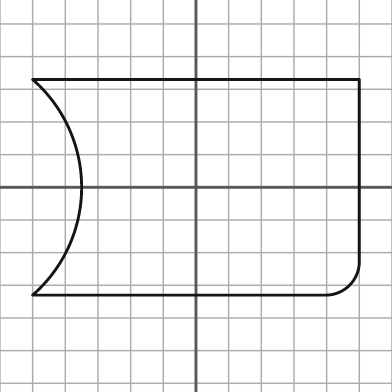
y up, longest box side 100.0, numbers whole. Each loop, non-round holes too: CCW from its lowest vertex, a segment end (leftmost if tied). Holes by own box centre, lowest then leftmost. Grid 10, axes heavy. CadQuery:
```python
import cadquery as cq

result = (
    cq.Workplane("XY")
    .moveTo(-50.0, -33.0)
    .lineTo(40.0, -33.0)
    .threePointArc((47.0, -30.0), (50.0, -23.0))
    .lineTo(50.0, 33.0)
    .lineTo(-50.0, 33.0)
    .threePointArc((-35.0, 0.0), (-50.0, -33.0))
    .close()
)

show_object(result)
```